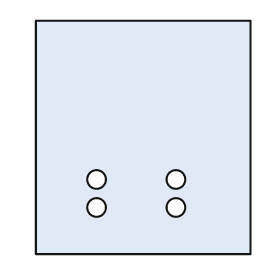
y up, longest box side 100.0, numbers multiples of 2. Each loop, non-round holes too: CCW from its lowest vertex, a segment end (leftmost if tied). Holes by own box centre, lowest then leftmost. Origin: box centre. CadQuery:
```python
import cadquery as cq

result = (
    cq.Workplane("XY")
    .moveTo(-46.0, -50.0)
    .lineTo(46.0, -50.0)
    .lineTo(46.0, 50.0)
    .lineTo(-46.0, 50.0)
    .close()
    .moveTo(-20.0, -30.0)
    .circle(4.0)
    .moveTo(14.0, -30.0)
    .circle(4.0)
    .moveTo(-20.0, -18.0)
    .circle(4.0)
    .moveTo(14.0, -18.0)
    .circle(4.0)
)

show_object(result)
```